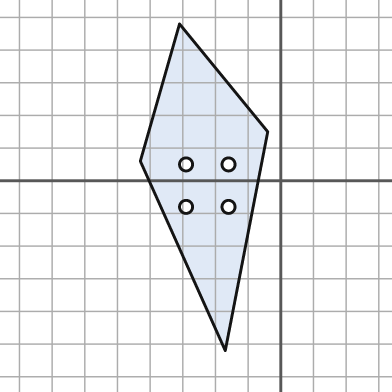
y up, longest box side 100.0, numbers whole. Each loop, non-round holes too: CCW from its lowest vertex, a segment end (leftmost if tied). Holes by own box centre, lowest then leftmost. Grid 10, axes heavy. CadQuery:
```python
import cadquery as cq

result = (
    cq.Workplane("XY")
    .moveTo(-17.0, -52.0)
    .lineTo(-4.0, 15.0)
    .lineTo(-31.0, 48.0)
    .lineTo(-43.0, 6.0)
    .close()
    .moveTo(-29.0, -8.0)
    .circle(2.0)
    .moveTo(-16.0, -8.0)
    .circle(2.0)
    .moveTo(-29.0, 5.0)
    .circle(2.0)
    .moveTo(-16.0, 5.0)
    .circle(2.0)
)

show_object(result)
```